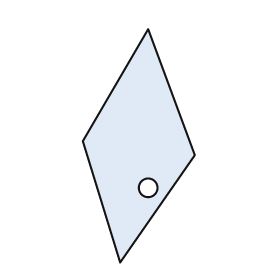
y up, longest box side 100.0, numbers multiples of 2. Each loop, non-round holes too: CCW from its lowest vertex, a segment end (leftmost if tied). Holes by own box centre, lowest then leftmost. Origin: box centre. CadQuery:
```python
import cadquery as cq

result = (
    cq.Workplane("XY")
    .moveTo(-8.0, -50.0)
    .lineTo(24.0, -4.0)
    .lineTo(4.0, 50.0)
    .lineTo(-24.0, 2.0)
    .close()
    .moveTo(4.0, -18.0)
    .circle(4.0)
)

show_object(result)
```